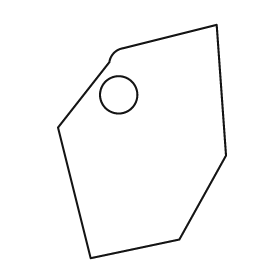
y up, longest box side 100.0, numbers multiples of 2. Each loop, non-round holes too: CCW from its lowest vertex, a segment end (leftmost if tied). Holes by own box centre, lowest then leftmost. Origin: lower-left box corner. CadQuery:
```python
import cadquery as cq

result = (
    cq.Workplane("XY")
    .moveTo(14.0, 0.0)
    .lineTo(52.0, 8.0)
    .lineTo(72.0, 44.0)
    .lineTo(68.0, 100.0)
    .lineTo(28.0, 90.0)
    .threePointArc((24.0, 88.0), (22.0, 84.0))
    .lineTo(0.0, 56.0)
    .close()
    .moveTo(26.0, 70.0)
    .circle(8.0)
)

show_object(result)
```